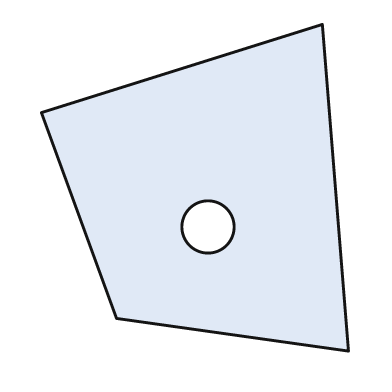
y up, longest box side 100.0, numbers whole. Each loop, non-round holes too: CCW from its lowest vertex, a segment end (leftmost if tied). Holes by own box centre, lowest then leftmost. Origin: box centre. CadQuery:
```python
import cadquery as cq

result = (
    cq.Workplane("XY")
    .moveTo(47.0, -50.0)
    .lineTo(39.0, 50.0)
    .lineTo(-47.0, 23.0)
    .lineTo(-24.0, -40.0)
    .close()
    .moveTo(4.0, -12.0)
    .circle(8.0)
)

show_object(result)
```